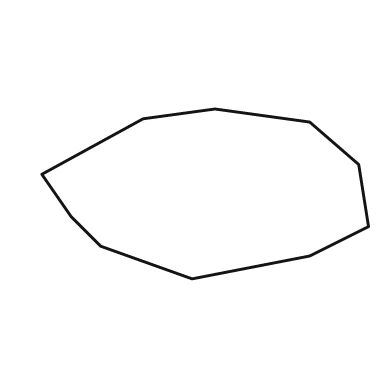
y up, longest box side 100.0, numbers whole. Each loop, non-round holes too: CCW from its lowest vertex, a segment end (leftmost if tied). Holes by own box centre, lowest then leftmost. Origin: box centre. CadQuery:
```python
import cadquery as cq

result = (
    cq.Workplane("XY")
    .moveTo(-4.0, -26.0)
    .lineTo(32.0, -19.0)
    .lineTo(50.0, -10.0)
    .lineTo(47.0, 9.0)
    .lineTo(32.0, 22.0)
    .lineTo(3.0, 26.0)
    .lineTo(-19.0, 23.0)
    .lineTo(-50.0, 6.0)
    .lineTo(-41.0, -7.0)
    .lineTo(-32.0, -16.0)
    .close()
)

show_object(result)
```